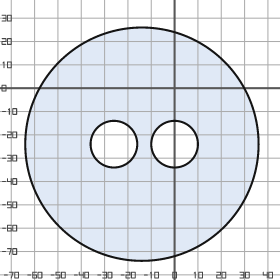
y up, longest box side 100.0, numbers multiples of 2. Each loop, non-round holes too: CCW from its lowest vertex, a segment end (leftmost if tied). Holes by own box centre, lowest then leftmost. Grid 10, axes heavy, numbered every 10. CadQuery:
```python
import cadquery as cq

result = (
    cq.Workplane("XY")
    .moveTo(-14.0, -24.0)
    .circle(50.0)
    .moveTo(-26.0, -24.0)
    .circle(10.0)
    .moveTo(0.0, -24.0)
    .circle(10.0)
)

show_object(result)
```